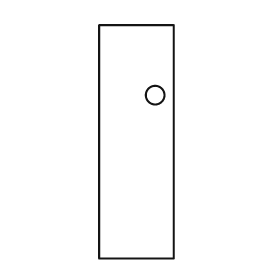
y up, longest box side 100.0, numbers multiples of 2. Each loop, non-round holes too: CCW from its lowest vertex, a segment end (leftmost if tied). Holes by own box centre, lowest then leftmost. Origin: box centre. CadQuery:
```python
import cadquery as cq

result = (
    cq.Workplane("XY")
    .moveTo(-16.0, -50.0)
    .lineTo(16.0, -50.0)
    .lineTo(16.0, 50.0)
    .lineTo(-16.0, 50.0)
    .close()
    .moveTo(8.0, 20.0)
    .circle(4.0)
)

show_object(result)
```